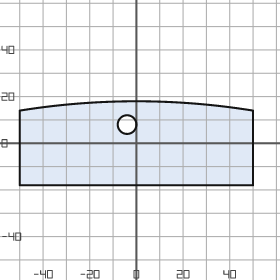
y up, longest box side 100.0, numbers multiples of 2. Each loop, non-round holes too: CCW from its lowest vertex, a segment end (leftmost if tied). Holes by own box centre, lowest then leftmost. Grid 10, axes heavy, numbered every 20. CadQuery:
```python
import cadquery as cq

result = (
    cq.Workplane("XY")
    .moveTo(-50.0, -18.0)
    .lineTo(50.0, -18.0)
    .lineTo(50.0, 14.0)
    .threePointArc((0.0, 18.0), (-50.0, 14.0))
    .close()
    .moveTo(-4.0, 8.0)
    .circle(4.0)
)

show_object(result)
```